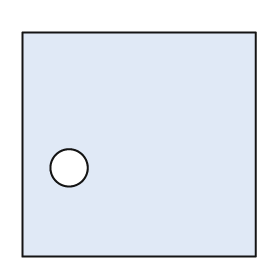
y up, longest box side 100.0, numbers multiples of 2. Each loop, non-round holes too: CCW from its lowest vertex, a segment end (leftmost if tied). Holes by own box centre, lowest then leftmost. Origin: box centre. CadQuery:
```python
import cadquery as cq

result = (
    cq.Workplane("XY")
    .moveTo(-50.0, -48.0)
    .lineTo(50.0, -48.0)
    .lineTo(50.0, 48.0)
    .lineTo(-50.0, 48.0)
    .close()
    .moveTo(-30.0, -10.0)
    .circle(8.0)
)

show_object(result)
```